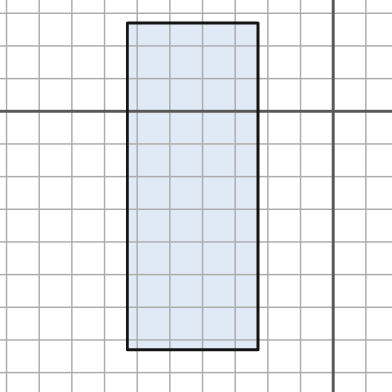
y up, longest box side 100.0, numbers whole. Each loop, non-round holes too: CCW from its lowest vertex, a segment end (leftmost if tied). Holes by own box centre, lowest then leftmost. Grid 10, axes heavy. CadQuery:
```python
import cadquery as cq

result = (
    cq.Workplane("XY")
    .moveTo(-63.0, -73.0)
    .lineTo(-23.0, -73.0)
    .lineTo(-23.0, 27.0)
    .lineTo(-63.0, 27.0)
    .close()
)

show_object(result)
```